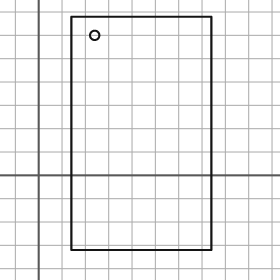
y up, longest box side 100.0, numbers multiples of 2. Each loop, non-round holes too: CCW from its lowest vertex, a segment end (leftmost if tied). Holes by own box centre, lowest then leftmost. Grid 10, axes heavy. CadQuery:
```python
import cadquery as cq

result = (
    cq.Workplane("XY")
    .moveTo(14.0, -32.0)
    .lineTo(74.0, -32.0)
    .lineTo(74.0, 68.0)
    .lineTo(14.0, 68.0)
    .close()
    .moveTo(24.0, 60.0)
    .circle(2.0)
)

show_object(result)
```